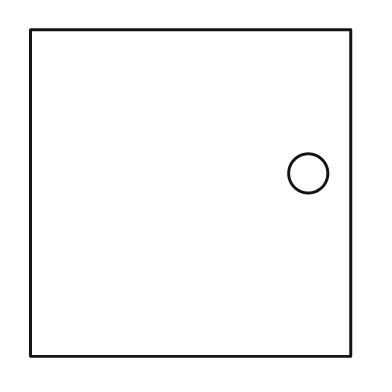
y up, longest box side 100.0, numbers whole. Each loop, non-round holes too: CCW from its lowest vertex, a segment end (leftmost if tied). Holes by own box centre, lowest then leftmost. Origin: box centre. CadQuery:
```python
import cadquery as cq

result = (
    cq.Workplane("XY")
    .moveTo(-49.0, -50.0)
    .lineTo(49.0, -50.0)
    .lineTo(49.0, 50.0)
    .lineTo(-49.0, 50.0)
    .close()
    .moveTo(36.0, 6.0)
    .circle(6.0)
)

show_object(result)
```